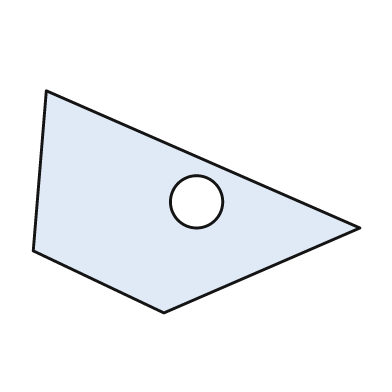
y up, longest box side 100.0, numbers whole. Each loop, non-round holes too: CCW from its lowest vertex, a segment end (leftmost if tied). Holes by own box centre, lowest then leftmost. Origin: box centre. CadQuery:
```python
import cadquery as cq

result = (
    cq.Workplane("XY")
    .moveTo(-10.0, -34.0)
    .lineTo(50.0, -8.0)
    .lineTo(-46.0, 34.0)
    .lineTo(-50.0, -15.0)
    .close()
    .moveTo(0.0, 0.0)
    .circle(8.0)
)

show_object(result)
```